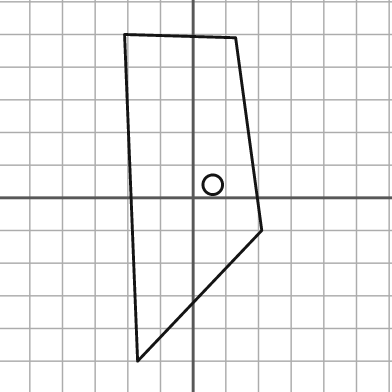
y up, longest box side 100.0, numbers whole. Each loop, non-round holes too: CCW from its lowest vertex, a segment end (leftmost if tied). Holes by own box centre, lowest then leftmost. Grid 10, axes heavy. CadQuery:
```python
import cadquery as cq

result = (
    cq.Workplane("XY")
    .moveTo(-17.0, -50.0)
    .lineTo(21.0, -10.0)
    .lineTo(13.0, 49.0)
    .lineTo(-21.0, 50.0)
    .close()
    .moveTo(6.0, 4.0)
    .circle(3.0)
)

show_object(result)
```